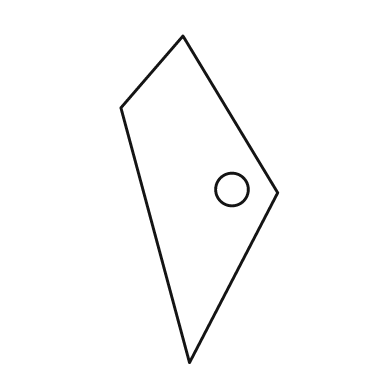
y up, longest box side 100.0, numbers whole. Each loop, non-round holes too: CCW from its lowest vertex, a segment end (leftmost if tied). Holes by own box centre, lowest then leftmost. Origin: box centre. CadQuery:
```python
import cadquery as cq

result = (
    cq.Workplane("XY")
    .moveTo(-3.0, -50.0)
    .lineTo(24.0, 2.0)
    .lineTo(-5.0, 50.0)
    .lineTo(-24.0, 28.0)
    .close()
    .moveTo(10.0, 3.0)
    .circle(5.0)
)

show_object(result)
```